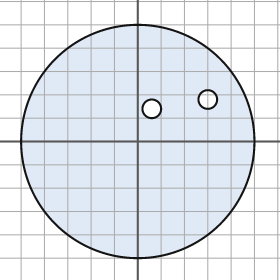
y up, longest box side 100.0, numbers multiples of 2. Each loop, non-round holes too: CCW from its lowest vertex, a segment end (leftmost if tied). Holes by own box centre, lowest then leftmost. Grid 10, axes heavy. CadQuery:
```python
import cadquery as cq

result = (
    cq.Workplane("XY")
    .moveTo(0.0, 0.0)
    .circle(50.0)
    .moveTo(6.0, 14.0)
    .circle(4.0)
    .moveTo(30.0, 18.0)
    .circle(4.0)
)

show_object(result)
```